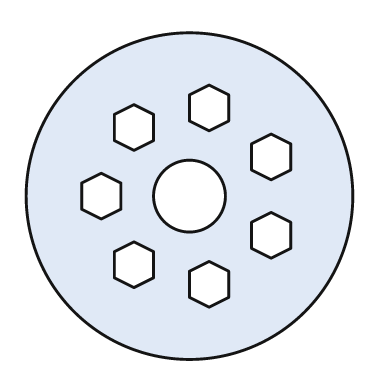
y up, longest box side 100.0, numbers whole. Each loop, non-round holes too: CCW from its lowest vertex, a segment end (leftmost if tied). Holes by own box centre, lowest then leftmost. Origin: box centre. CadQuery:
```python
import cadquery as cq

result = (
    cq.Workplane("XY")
    .moveTo(0.0, 0.0)
    .circle(50.0)
    .moveTo(6.0, -34.0)
    .lineTo(12.0, -31.0)
    .lineTo(12.0, -23.0)
    .lineTo(6.0, -20.0)
    .lineTo(0.0, -23.0)
    .lineTo(0.0, -31.0)
    .close()
    .moveTo(-17.0, -28.0)
    .lineTo(-11.0, -25.0)
    .lineTo(-11.0, -17.0)
    .lineTo(-17.0, -14.0)
    .lineTo(-23.0, -17.0)
    .lineTo(-23.0, -25.0)
    .close()
    .moveTo(25.0, -19.0)
    .lineTo(31.0, -16.0)
    .lineTo(31.0, -8.0)
    .lineTo(25.0, -5.0)
    .lineTo(19.0, -8.0)
    .lineTo(19.0, -16.0)
    .close()
    .moveTo(-27.0, -7.0)
    .lineTo(-21.0, -4.0)
    .lineTo(-21.0, 4.0)
    .lineTo(-27.0, 7.0)
    .lineTo(-33.0, 4.0)
    .lineTo(-33.0, -4.0)
    .close()
    .moveTo(0.0, 0.0)
    .circle(11.0)
    .moveTo(25.0, 5.0)
    .lineTo(31.0, 8.0)
    .lineTo(31.0, 16.0)
    .lineTo(25.0, 19.0)
    .lineTo(19.0, 16.0)
    .lineTo(19.0, 8.0)
    .close()
    .moveTo(-17.0, 14.0)
    .lineTo(-11.0, 17.0)
    .lineTo(-11.0, 25.0)
    .lineTo(-17.0, 28.0)
    .lineTo(-23.0, 25.0)
    .lineTo(-23.0, 17.0)
    .close()
    .moveTo(6.0, 20.0)
    .lineTo(12.0, 23.0)
    .lineTo(12.0, 31.0)
    .lineTo(6.0, 34.0)
    .lineTo(0.0, 31.0)
    .lineTo(0.0, 23.0)
    .close()
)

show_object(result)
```